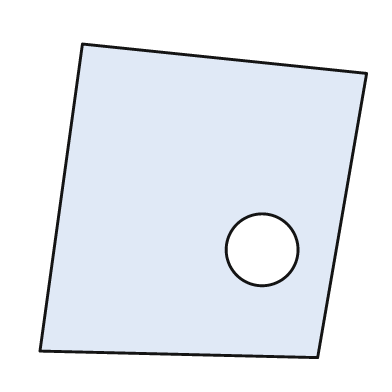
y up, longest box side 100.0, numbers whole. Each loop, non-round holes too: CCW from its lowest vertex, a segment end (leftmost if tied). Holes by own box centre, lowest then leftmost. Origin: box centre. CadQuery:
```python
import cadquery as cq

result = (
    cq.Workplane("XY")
    .moveTo(35.0, -48.0)
    .lineTo(50.0, 39.0)
    .lineTo(-37.0, 48.0)
    .lineTo(-50.0, -46.0)
    .close()
    .moveTo(18.0, -15.0)
    .circle(11.0)
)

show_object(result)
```